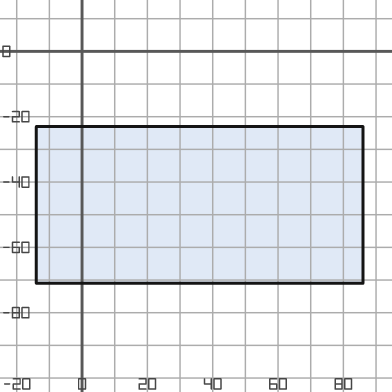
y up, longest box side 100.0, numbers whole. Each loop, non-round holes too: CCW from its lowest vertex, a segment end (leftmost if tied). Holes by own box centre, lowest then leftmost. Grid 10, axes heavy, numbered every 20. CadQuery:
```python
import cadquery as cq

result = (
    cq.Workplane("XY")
    .moveTo(-14.0, -71.0)
    .lineTo(86.0, -71.0)
    .lineTo(86.0, -23.0)
    .lineTo(-14.0, -23.0)
    .close()
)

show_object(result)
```